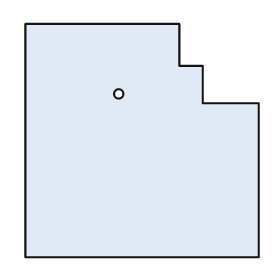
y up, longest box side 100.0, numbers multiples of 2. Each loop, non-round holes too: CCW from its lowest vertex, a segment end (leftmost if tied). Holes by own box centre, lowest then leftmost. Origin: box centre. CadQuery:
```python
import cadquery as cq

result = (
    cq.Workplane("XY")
    .moveTo(-50.0, -50.0)
    .lineTo(50.0, -50.0)
    .lineTo(50.0, 16.0)
    .lineTo(26.0, 16.0)
    .lineTo(26.0, 32.0)
    .lineTo(16.0, 32.0)
    .lineTo(16.0, 50.0)
    .lineTo(-50.0, 50.0)
    .close()
    .moveTo(-10.0, 20.0)
    .circle(2.0)
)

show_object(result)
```